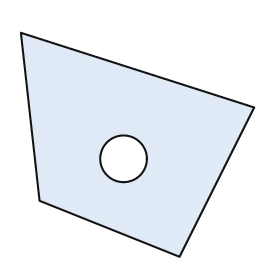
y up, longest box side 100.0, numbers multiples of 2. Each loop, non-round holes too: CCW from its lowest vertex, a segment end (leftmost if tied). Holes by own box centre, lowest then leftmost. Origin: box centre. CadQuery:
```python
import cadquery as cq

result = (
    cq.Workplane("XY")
    .moveTo(18.0, -48.0)
    .lineTo(50.0, 16.0)
    .lineTo(-50.0, 48.0)
    .lineTo(-42.0, -24.0)
    .close()
    .moveTo(-6.0, -6.0)
    .circle(10.0)
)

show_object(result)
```